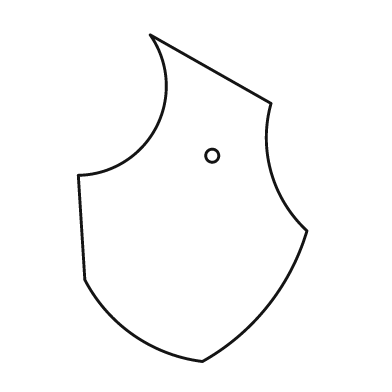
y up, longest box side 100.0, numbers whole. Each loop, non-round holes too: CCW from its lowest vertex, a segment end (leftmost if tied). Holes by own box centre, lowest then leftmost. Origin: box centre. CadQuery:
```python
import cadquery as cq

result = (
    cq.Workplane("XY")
    .moveTo(3.0, -50.0)
    .threePointArc((23.0, -33.0), (35.0, -10.0))
    .threePointArc((24.0, 8.0), (24.0, 29.0))
    .lineTo(-13.0, 50.0)
    .threePointArc((-11.0, 22.0), (-35.0, 7.0))
    .lineTo(-33.0, -25.0)
    .threePointArc((-18.0, -42.0), (3.0, -50.0))
    .close()
    .moveTo(6.0, 13.0)
    .circle(2.0)
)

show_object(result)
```